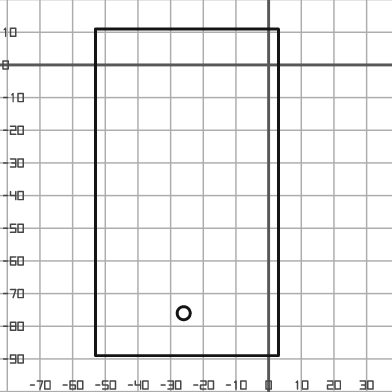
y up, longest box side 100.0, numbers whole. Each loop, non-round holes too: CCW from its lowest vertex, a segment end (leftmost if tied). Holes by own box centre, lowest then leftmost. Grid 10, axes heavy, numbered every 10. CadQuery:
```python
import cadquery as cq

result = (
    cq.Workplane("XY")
    .moveTo(-53.0, -89.0)
    .lineTo(3.0, -89.0)
    .lineTo(3.0, 11.0)
    .lineTo(-53.0, 11.0)
    .close()
    .moveTo(-26.0, -76.0)
    .circle(2.0)
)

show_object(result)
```